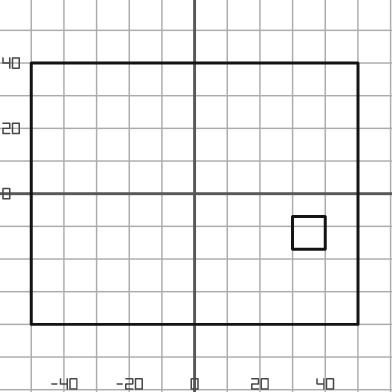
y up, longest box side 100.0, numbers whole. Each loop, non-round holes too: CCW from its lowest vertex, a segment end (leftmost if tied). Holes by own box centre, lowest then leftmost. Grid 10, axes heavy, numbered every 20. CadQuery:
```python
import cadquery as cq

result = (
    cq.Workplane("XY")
    .moveTo(-50.0, -40.0)
    .lineTo(50.0, -40.0)
    .lineTo(50.0, 40.0)
    .lineTo(-50.0, 40.0)
    .close()
    .moveTo(30.0, -17.0)
    .lineTo(40.0, -17.0)
    .lineTo(40.0, -7.0)
    .lineTo(30.0, -7.0)
    .close()
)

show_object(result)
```